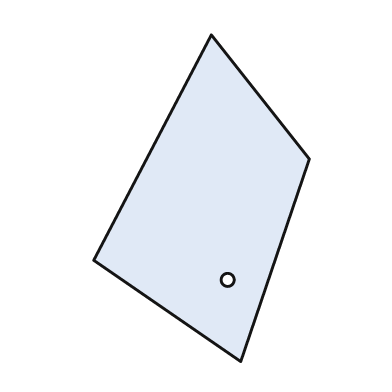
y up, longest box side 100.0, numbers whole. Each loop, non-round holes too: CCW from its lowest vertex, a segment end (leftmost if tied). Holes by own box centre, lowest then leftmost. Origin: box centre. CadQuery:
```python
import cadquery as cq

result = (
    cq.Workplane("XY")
    .moveTo(12.0, -50.0)
    .lineTo(33.0, 12.0)
    .lineTo(3.0, 50.0)
    .lineTo(-33.0, -19.0)
    .close()
    .moveTo(8.0, -25.0)
    .circle(2.0)
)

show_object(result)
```